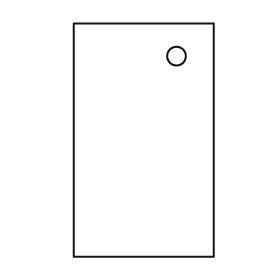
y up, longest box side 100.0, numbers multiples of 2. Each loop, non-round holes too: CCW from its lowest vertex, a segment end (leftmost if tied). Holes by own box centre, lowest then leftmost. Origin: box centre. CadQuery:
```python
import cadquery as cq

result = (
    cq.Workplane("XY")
    .moveTo(-30.0, -50.0)
    .lineTo(30.0, -50.0)
    .lineTo(30.0, 50.0)
    .lineTo(-30.0, 50.0)
    .close()
    .moveTo(14.0, 36.0)
    .circle(4.0)
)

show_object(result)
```